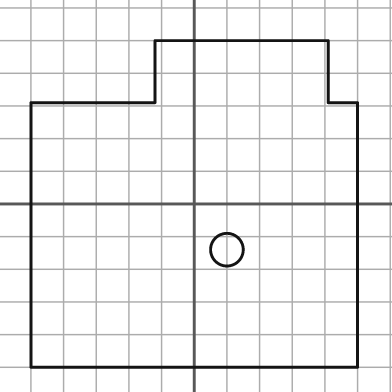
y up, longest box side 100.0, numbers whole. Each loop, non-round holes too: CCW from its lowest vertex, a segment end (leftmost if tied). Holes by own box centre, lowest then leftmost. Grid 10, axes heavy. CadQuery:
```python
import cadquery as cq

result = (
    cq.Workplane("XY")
    .moveTo(-50.0, -50.0)
    .lineTo(50.0, -50.0)
    .lineTo(50.0, 31.0)
    .lineTo(41.0, 31.0)
    .lineTo(41.0, 50.0)
    .lineTo(-12.0, 50.0)
    .lineTo(-12.0, 31.0)
    .lineTo(-50.0, 31.0)
    .close()
    .moveTo(10.0, -14.0)
    .circle(5.0)
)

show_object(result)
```